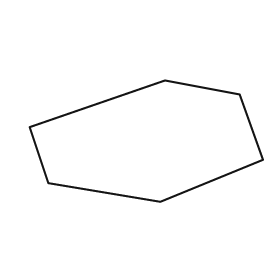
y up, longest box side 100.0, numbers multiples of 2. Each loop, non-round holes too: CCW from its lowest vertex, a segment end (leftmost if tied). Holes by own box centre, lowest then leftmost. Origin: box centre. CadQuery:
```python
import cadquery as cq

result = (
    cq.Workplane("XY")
    .moveTo(6.0, -26.0)
    .lineTo(50.0, -8.0)
    .lineTo(40.0, 20.0)
    .lineTo(8.0, 26.0)
    .lineTo(-50.0, 6.0)
    .lineTo(-42.0, -18.0)
    .close()
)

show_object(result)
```